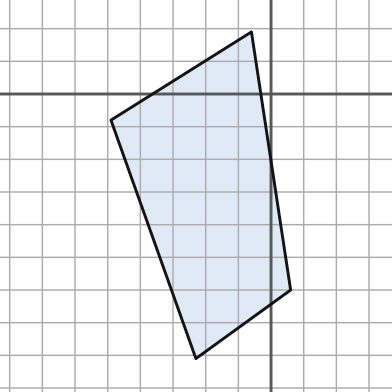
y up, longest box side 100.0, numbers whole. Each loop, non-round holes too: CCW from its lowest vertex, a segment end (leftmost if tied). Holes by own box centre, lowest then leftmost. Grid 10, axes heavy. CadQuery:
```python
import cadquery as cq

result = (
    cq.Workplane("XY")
    .moveTo(-23.0, -81.0)
    .lineTo(6.0, -60.0)
    .lineTo(-6.0, 19.0)
    .lineTo(-49.0, -8.0)
    .close()
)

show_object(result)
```